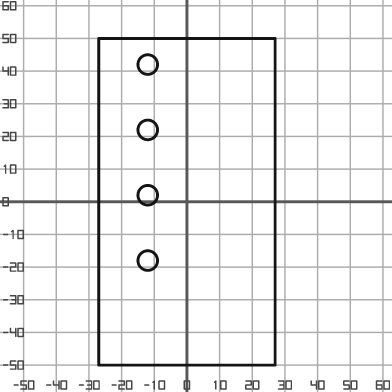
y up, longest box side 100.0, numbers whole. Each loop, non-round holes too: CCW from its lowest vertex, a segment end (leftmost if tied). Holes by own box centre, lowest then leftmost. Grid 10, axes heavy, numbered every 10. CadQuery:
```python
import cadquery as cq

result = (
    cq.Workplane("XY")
    .moveTo(-27.0, -50.0)
    .lineTo(27.0, -50.0)
    .lineTo(27.0, 50.0)
    .lineTo(-27.0, 50.0)
    .close()
    .moveTo(-12.0, -18.0)
    .circle(3.0)
    .moveTo(-12.0, 2.0)
    .circle(3.0)
    .moveTo(-12.0, 22.0)
    .circle(3.0)
    .moveTo(-12.0, 42.0)
    .circle(3.0)
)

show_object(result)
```